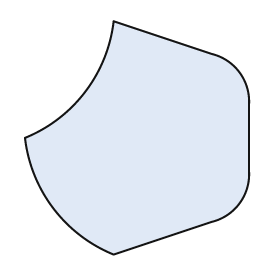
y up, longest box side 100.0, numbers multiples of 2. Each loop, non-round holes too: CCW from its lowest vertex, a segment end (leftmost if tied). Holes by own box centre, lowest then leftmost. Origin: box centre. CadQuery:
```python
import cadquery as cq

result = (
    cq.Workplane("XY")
    .moveTo(-10.0, -50.0)
    .lineTo(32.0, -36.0)
    .threePointArc((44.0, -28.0), (48.0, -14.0))
    .lineTo(48.0, 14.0)
    .threePointArc((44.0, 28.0), (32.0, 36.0))
    .lineTo(-10.0, 50.0)
    .threePointArc((-22.0, 20.0), (-48.0, 0.0))
    .threePointArc((-36.0, -30.0), (-10.0, -50.0))
    .close()
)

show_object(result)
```